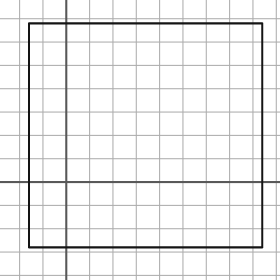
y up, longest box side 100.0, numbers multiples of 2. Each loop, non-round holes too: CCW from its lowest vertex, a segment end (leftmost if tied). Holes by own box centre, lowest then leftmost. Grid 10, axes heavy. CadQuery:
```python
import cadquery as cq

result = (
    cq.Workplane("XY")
    .moveTo(-16.0, -28.0)
    .lineTo(84.0, -28.0)
    .lineTo(84.0, 68.0)
    .lineTo(-16.0, 68.0)
    .close()
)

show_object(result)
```